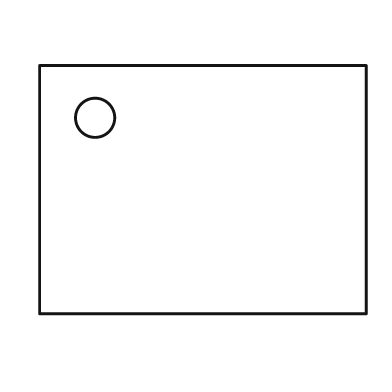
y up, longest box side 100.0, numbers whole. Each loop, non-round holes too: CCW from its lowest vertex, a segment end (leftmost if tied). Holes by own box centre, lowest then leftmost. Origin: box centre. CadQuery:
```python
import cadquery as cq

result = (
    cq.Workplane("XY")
    .moveTo(-50.0, -38.0)
    .lineTo(50.0, -38.0)
    .lineTo(50.0, 38.0)
    .lineTo(-50.0, 38.0)
    .close()
    .moveTo(-33.0, 22.0)
    .circle(6.0)
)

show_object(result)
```